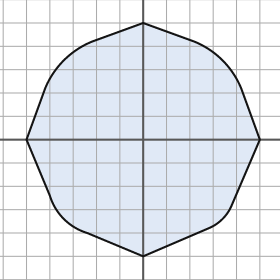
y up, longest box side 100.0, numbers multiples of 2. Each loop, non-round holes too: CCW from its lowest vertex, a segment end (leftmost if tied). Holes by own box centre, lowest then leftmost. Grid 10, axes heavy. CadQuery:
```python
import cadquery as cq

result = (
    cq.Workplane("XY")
    .moveTo(0.0, -50.0)
    .lineTo(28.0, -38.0)
    .threePointArc((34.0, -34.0), (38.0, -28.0))
    .lineTo(50.0, 0.0)
    .lineTo(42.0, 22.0)
    .threePointArc((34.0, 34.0), (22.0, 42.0))
    .lineTo(0.0, 50.0)
    .lineTo(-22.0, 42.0)
    .threePointArc((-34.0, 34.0), (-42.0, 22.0))
    .lineTo(-50.0, 0.0)
    .lineTo(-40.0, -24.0)
    .threePointArc((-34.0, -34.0), (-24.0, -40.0))
    .close()
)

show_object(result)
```